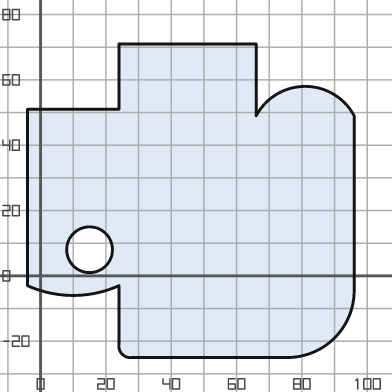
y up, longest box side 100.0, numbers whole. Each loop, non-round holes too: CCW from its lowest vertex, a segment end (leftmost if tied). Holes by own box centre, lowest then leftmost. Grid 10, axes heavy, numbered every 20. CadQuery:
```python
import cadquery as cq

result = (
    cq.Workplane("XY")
    .moveTo(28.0, -25.0)
    .lineTo(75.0, -25.0)
    .threePointArc((90.0, -19.0), (96.0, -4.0))
    .lineTo(96.0, 49.0)
    .threePointArc((81.0, 58.0), (66.0, 49.0))
    .lineTo(66.0, 71.0)
    .lineTo(24.0, 71.0)
    .lineTo(24.0, 51.0)
    .lineTo(-4.0, 51.0)
    .lineTo(-4.0, -3.0)
    .threePointArc((10.0, -6.0), (24.0, -3.0))
    .lineTo(24.0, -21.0)
    .threePointArc((25.0, -24.0), (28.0, -25.0))
    .close()
    .moveTo(15.0, 8.0)
    .circle(7.0)
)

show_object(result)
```